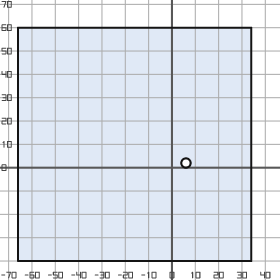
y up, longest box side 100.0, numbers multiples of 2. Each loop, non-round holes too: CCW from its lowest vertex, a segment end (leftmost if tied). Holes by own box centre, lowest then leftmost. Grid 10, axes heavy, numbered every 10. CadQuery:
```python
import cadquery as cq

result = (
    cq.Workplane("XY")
    .moveTo(-66.0, -40.0)
    .lineTo(34.0, -40.0)
    .lineTo(34.0, 60.0)
    .lineTo(-66.0, 60.0)
    .close()
    .moveTo(6.0, 2.0)
    .circle(2.0)
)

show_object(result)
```